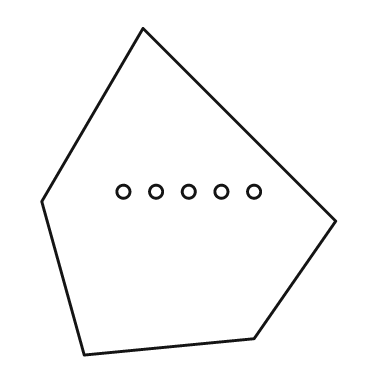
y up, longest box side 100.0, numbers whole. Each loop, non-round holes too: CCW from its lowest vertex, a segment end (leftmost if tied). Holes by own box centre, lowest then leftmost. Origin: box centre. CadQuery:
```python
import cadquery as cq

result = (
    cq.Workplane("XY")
    .moveTo(-32.0, -50.0)
    .lineTo(20.0, -45.0)
    .lineTo(45.0, -9.0)
    .lineTo(-14.0, 50.0)
    .lineTo(-45.0, -3.0)
    .close()
    .moveTo(-20.0, 0.0)
    .circle(2.0)
    .moveTo(-10.0, 0.0)
    .circle(2.0)
    .moveTo(0.0, 0.0)
    .circle(2.0)
    .moveTo(10.0, 0.0)
    .circle(2.0)
    .moveTo(20.0, 0.0)
    .circle(2.0)
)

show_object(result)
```